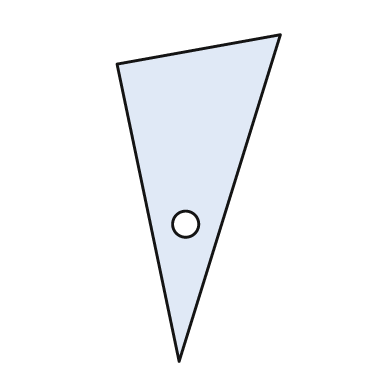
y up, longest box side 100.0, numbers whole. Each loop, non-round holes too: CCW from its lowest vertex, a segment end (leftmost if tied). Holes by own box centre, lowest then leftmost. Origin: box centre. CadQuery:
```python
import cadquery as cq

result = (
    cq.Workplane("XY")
    .moveTo(-6.0, -50.0)
    .lineTo(25.0, 50.0)
    .lineTo(-25.0, 41.0)
    .close()
    .moveTo(-4.0, -8.0)
    .circle(4.0)
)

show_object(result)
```